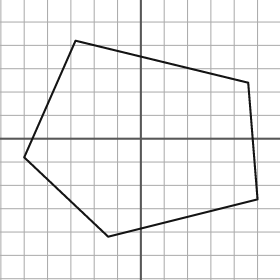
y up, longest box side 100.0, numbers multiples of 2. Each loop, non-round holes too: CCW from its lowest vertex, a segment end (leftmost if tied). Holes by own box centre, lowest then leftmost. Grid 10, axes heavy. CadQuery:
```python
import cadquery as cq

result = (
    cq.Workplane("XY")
    .moveTo(-14.0, -42.0)
    .lineTo(50.0, -26.0)
    .lineTo(46.0, 24.0)
    .lineTo(-28.0, 42.0)
    .lineTo(-50.0, -8.0)
    .close()
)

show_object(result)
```